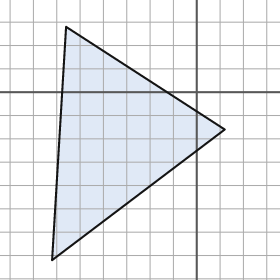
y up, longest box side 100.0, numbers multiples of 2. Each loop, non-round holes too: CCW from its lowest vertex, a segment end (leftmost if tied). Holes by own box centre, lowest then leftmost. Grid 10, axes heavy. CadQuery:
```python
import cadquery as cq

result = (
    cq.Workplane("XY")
    .moveTo(-62.0, -72.0)
    .lineTo(12.0, -16.0)
    .lineTo(-56.0, 28.0)
    .close()
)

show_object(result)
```